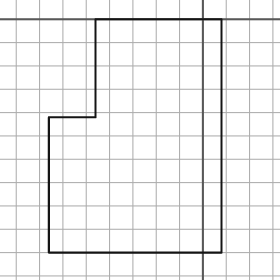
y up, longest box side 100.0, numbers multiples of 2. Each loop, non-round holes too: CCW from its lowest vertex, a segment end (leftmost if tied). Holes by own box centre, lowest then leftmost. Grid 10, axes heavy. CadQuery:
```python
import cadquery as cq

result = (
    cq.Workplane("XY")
    .moveTo(-66.0, -100.0)
    .lineTo(8.0, -100.0)
    .lineTo(8.0, 0.0)
    .lineTo(-46.0, 0.0)
    .lineTo(-46.0, -42.0)
    .lineTo(-66.0, -42.0)
    .close()
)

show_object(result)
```